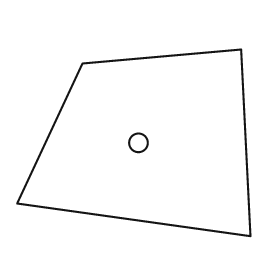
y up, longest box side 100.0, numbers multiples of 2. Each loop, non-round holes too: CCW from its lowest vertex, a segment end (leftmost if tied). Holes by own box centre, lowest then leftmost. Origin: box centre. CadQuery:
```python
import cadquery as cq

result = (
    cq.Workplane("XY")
    .moveTo(50.0, -40.0)
    .lineTo(46.0, 40.0)
    .lineTo(-22.0, 34.0)
    .lineTo(-50.0, -26.0)
    .close()
    .moveTo(2.0, 0.0)
    .circle(4.0)
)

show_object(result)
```